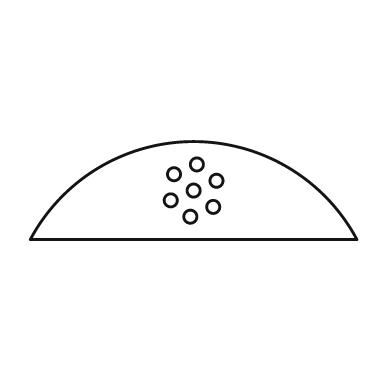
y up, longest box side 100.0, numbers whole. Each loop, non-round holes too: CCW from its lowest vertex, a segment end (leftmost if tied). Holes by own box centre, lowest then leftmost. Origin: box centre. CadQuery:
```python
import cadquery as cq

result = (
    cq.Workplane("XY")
    .moveTo(-50.0, -15.0)
    .lineTo(50.0, -15.0)
    .threePointArc((0.0, 15.0), (-50.0, -15.0))
    .close()
    .moveTo(-1.0, -8.0)
    .circle(2.0)
    .moveTo(6.0, -5.0)
    .circle(2.0)
    .moveTo(-7.0, -3.0)
    .circle(2.0)
    .moveTo(0.0, 0.0)
    .circle(2.0)
    .moveTo(7.0, 3.0)
    .circle(2.0)
    .moveTo(-6.0, 5.0)
    .circle(2.0)
    .moveTo(1.0, 8.0)
    .circle(2.0)
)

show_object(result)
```